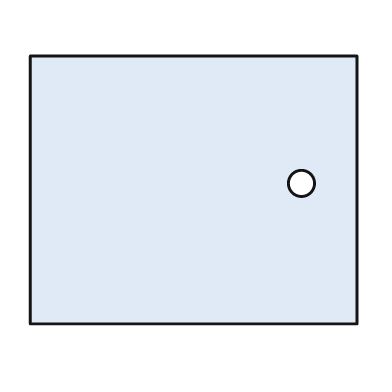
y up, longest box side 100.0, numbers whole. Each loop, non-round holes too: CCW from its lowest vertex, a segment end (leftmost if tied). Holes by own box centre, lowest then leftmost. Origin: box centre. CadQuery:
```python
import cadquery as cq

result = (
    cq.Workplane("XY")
    .moveTo(-50.0, -41.0)
    .lineTo(50.0, -41.0)
    .lineTo(50.0, 41.0)
    .lineTo(-50.0, 41.0)
    .close()
    .moveTo(33.0, 2.0)
    .circle(4.0)
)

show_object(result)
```